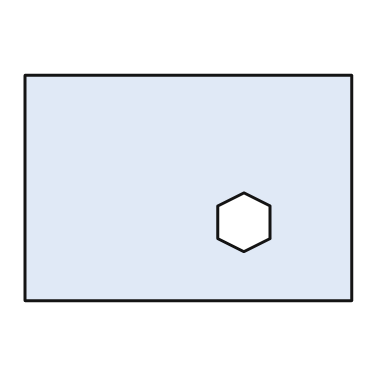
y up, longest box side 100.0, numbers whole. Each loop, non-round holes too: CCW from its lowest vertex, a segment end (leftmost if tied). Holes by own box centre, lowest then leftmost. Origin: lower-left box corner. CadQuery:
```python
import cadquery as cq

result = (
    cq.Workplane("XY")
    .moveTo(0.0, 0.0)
    .lineTo(100.0, 0.0)
    .lineTo(100.0, 69.0)
    .lineTo(0.0, 69.0)
    .close()
    .moveTo(67.0, 15.0)
    .lineTo(75.0, 19.0)
    .lineTo(75.0, 29.0)
    .lineTo(67.0, 33.0)
    .lineTo(59.0, 29.0)
    .lineTo(59.0, 19.0)
    .close()
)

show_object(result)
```